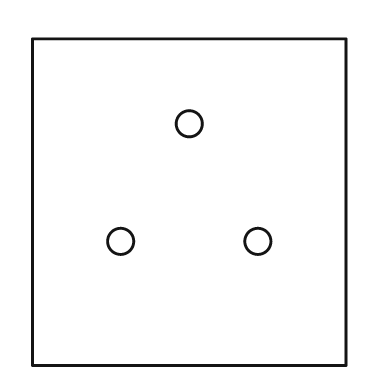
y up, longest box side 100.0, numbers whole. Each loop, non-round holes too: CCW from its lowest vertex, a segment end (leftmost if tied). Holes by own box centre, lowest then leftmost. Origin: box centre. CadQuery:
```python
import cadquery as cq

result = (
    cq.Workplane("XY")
    .moveTo(-48.0, -50.0)
    .lineTo(48.0, -50.0)
    .lineTo(48.0, 50.0)
    .lineTo(-48.0, 50.0)
    .close()
    .moveTo(-21.0, -12.0)
    .circle(4.0)
    .moveTo(21.0, -12.0)
    .circle(4.0)
    .moveTo(0.0, 24.0)
    .circle(4.0)
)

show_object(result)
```